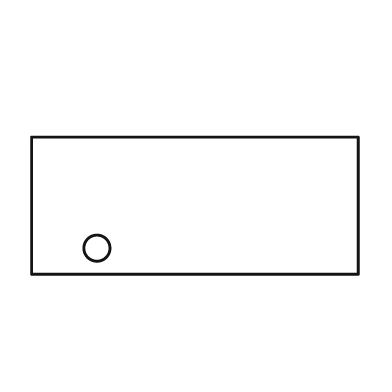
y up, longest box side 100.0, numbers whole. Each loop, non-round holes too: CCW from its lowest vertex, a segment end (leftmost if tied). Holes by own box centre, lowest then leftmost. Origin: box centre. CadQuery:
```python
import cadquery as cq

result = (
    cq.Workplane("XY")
    .moveTo(-50.0, -21.0)
    .lineTo(50.0, -21.0)
    .lineTo(50.0, 21.0)
    .lineTo(-50.0, 21.0)
    .close()
    .moveTo(-30.0, -13.0)
    .circle(4.0)
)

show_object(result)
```